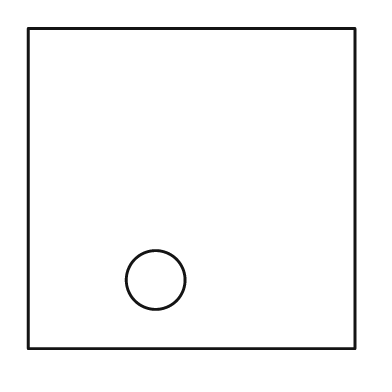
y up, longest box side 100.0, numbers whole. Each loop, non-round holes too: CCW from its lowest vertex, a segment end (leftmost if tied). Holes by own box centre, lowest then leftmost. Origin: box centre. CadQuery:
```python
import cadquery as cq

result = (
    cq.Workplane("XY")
    .moveTo(-50.0, -49.0)
    .lineTo(50.0, -49.0)
    .lineTo(50.0, 49.0)
    .lineTo(-50.0, 49.0)
    .close()
    .moveTo(-11.0, -28.0)
    .circle(9.0)
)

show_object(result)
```